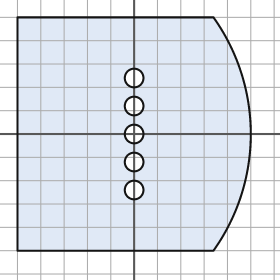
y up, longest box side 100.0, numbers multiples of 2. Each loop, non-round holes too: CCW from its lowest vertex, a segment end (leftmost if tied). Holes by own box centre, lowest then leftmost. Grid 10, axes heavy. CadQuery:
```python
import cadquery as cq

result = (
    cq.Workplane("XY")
    .moveTo(-50.0, -50.0)
    .lineTo(34.0, -50.0)
    .threePointArc((50.0, 0.0), (34.0, 50.0))
    .lineTo(-50.0, 50.0)
    .close()
    .moveTo(0.0, -24.0)
    .circle(4.0)
    .moveTo(0.0, -12.0)
    .circle(4.0)
    .moveTo(0.0, 0.0)
    .circle(4.0)
    .moveTo(0.0, 12.0)
    .circle(4.0)
    .moveTo(0.0, 24.0)
    .circle(4.0)
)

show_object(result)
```